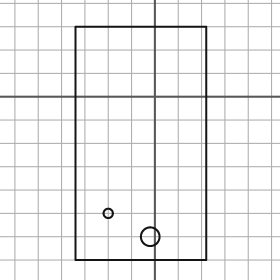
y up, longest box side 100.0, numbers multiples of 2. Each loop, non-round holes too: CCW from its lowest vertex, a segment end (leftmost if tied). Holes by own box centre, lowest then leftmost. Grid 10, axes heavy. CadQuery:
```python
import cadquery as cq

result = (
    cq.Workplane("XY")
    .moveTo(-34.0, -70.0)
    .lineTo(22.0, -70.0)
    .lineTo(22.0, 30.0)
    .lineTo(-34.0, 30.0)
    .close()
    .moveTo(-2.0, -60.0)
    .circle(4.0)
    .moveTo(-20.0, -50.0)
    .circle(2.0)
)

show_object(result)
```